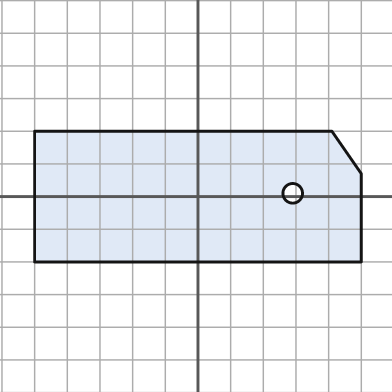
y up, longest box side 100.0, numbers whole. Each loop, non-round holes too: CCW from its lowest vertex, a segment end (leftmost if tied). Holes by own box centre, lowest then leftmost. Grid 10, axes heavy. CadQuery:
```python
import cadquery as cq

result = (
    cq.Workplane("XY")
    .moveTo(-50.0, -20.0)
    .lineTo(50.0, -20.0)
    .lineTo(50.0, 7.0)
    .lineTo(41.0, 20.0)
    .lineTo(-50.0, 20.0)
    .close()
    .moveTo(29.0, 1.0)
    .circle(3.0)
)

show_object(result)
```